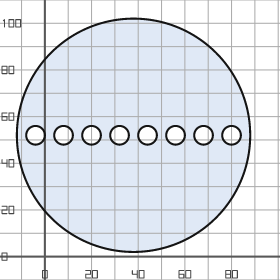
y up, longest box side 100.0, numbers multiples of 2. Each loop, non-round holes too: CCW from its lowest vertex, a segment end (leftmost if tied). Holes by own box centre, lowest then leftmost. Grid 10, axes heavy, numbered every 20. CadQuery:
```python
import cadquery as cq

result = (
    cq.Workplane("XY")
    .moveTo(38.0, 52.0)
    .circle(50.0)
    .moveTo(-4.0, 52.0)
    .circle(4.0)
    .moveTo(8.0, 52.0)
    .circle(4.0)
    .moveTo(20.0, 52.0)
    .circle(4.0)
    .moveTo(32.0, 52.0)
    .circle(4.0)
    .moveTo(44.0, 52.0)
    .circle(4.0)
    .moveTo(56.0, 52.0)
    .circle(4.0)
    .moveTo(68.0, 52.0)
    .circle(4.0)
    .moveTo(80.0, 52.0)
    .circle(4.0)
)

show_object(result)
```